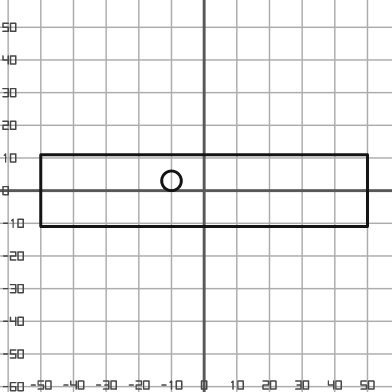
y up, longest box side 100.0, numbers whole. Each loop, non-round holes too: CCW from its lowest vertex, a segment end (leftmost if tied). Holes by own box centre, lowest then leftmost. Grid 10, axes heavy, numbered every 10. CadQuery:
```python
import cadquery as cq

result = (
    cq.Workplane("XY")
    .moveTo(-50.0, -11.0)
    .lineTo(50.0, -11.0)
    .lineTo(50.0, 11.0)
    .lineTo(-50.0, 11.0)
    .close()
    .moveTo(-10.0, 3.0)
    .circle(3.0)
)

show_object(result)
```